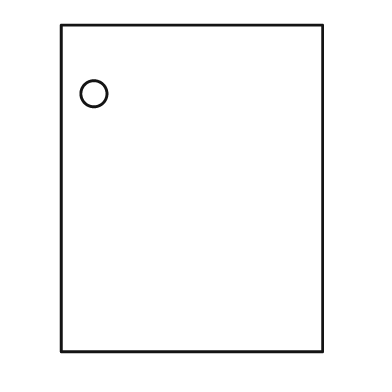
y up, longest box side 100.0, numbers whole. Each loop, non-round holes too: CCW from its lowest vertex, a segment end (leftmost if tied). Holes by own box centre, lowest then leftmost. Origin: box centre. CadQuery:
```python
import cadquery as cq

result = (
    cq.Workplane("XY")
    .moveTo(-40.0, -50.0)
    .lineTo(40.0, -50.0)
    .lineTo(40.0, 50.0)
    .lineTo(-40.0, 50.0)
    .close()
    .moveTo(-30.0, 29.0)
    .circle(4.0)
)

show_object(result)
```